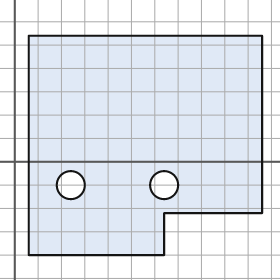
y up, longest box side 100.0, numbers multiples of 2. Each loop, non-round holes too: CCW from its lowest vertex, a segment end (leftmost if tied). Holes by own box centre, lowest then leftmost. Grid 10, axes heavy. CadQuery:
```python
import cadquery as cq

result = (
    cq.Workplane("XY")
    .moveTo(6.0, -40.0)
    .lineTo(64.0, -40.0)
    .lineTo(64.0, -22.0)
    .lineTo(106.0, -22.0)
    .lineTo(106.0, 54.0)
    .lineTo(6.0, 54.0)
    .close()
    .moveTo(24.0, -10.0)
    .circle(6.0)
    .moveTo(64.0, -10.0)
    .circle(6.0)
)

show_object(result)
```